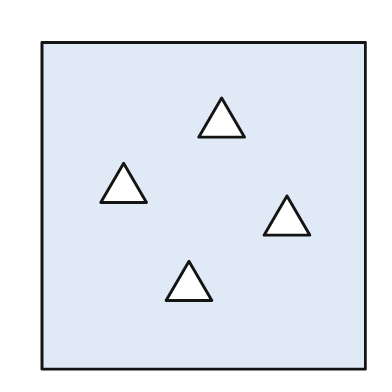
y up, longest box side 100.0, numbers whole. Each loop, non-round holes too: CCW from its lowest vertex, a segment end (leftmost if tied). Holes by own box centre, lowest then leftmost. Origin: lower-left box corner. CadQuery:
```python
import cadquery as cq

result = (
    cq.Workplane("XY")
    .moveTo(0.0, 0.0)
    .lineTo(99.0, 0.0)
    .lineTo(99.0, 100.0)
    .lineTo(0.0, 100.0)
    .close()
    .moveTo(38.0, 21.0)
    .lineTo(52.0, 21.0)
    .lineTo(45.0, 33.0)
    .close()
    .moveTo(68.0, 41.0)
    .lineTo(82.0, 41.0)
    .lineTo(75.0, 53.0)
    .close()
    .moveTo(18.0, 51.0)
    .lineTo(32.0, 51.0)
    .lineTo(25.0, 63.0)
    .close()
    .moveTo(48.0, 71.0)
    .lineTo(62.0, 71.0)
    .lineTo(55.0, 83.0)
    .close()
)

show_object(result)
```